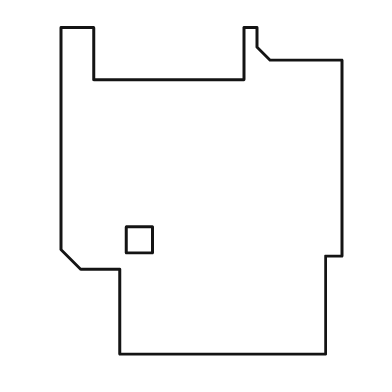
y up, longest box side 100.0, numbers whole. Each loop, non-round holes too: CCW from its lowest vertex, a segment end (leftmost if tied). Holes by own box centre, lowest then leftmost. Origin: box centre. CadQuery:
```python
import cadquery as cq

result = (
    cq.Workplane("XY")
    .moveTo(-25.0, -50.0)
    .lineTo(38.0, -50.0)
    .lineTo(38.0, -20.0)
    .lineTo(43.0, -20.0)
    .lineTo(43.0, 40.0)
    .lineTo(21.0, 40.0)
    .lineTo(17.0, 44.0)
    .lineTo(17.0, 50.0)
    .lineTo(13.0, 50.0)
    .lineTo(13.0, 34.0)
    .lineTo(-33.0, 34.0)
    .lineTo(-33.0, 50.0)
    .lineTo(-43.0, 50.0)
    .lineTo(-43.0, -18.0)
    .lineTo(-37.0, -24.0)
    .lineTo(-25.0, -24.0)
    .close()
    .moveTo(-23.0, -19.0)
    .lineTo(-15.0, -19.0)
    .lineTo(-15.0, -11.0)
    .lineTo(-23.0, -11.0)
    .close()
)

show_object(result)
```